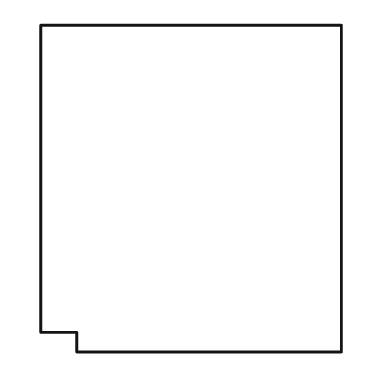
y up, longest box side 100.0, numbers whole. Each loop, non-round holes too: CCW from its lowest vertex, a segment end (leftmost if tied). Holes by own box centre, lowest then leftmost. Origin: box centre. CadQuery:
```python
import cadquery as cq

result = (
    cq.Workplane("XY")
    .moveTo(-35.0, -50.0)
    .lineTo(46.0, -50.0)
    .lineTo(46.0, 50.0)
    .lineTo(-46.0, 50.0)
    .lineTo(-46.0, -44.0)
    .lineTo(-35.0, -44.0)
    .close()
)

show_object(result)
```